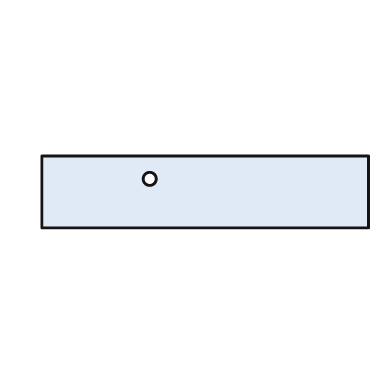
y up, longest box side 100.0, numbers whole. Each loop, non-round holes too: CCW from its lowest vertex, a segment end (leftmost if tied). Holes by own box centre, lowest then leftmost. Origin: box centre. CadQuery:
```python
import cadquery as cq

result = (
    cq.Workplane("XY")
    .moveTo(-50.0, -11.0)
    .lineTo(50.0, -11.0)
    .lineTo(50.0, 11.0)
    .lineTo(-50.0, 11.0)
    .close()
    .moveTo(-17.0, 4.0)
    .circle(2.0)
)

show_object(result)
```